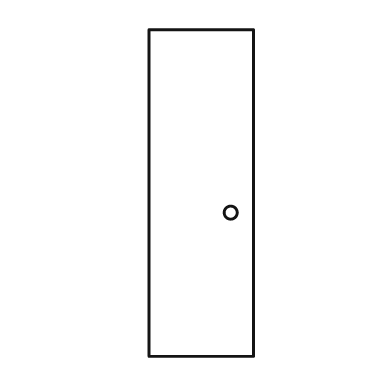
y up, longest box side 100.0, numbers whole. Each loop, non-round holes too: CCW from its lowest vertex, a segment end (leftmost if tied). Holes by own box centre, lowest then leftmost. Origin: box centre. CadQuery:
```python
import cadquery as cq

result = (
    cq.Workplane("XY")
    .moveTo(-16.0, -50.0)
    .lineTo(16.0, -50.0)
    .lineTo(16.0, 50.0)
    .lineTo(-16.0, 50.0)
    .close()
    .moveTo(9.0, -6.0)
    .circle(2.0)
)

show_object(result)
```